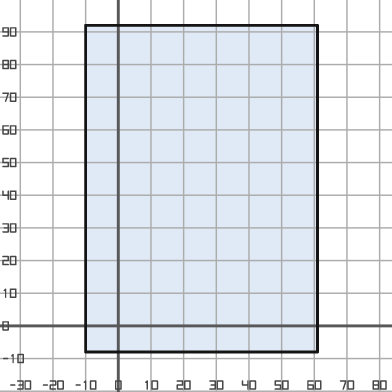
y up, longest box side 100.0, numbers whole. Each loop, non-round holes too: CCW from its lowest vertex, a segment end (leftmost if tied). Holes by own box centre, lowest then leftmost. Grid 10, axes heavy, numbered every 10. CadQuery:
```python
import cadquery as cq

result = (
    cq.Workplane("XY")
    .moveTo(-10.0, -8.0)
    .lineTo(61.0, -8.0)
    .lineTo(61.0, 92.0)
    .lineTo(-10.0, 92.0)
    .close()
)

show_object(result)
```